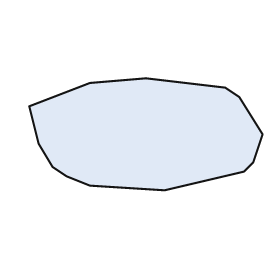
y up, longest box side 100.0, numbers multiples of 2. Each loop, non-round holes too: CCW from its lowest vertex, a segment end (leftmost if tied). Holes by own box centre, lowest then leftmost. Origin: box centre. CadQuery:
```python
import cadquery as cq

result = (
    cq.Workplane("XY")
    .moveTo(8.0, -24.0)
    .lineTo(42.0, -16.0)
    .lineTo(46.0, -12.0)
    .lineTo(50.0, 0.0)
    .lineTo(40.0, 16.0)
    .lineTo(34.0, 20.0)
    .lineTo(0.0, 24.0)
    .lineTo(-24.0, 22.0)
    .lineTo(-50.0, 12.0)
    .lineTo(-46.0, -4.0)
    .lineTo(-40.0, -14.0)
    .lineTo(-34.0, -18.0)
    .lineTo(-24.0, -22.0)
    .close()
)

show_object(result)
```